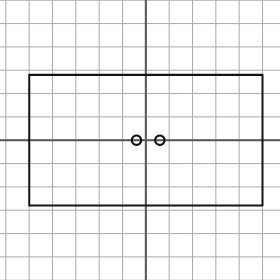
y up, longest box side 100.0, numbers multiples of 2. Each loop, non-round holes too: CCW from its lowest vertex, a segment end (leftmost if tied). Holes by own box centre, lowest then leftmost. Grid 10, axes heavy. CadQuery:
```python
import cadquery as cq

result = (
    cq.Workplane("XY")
    .moveTo(-50.0, -28.0)
    .lineTo(50.0, -28.0)
    .lineTo(50.0, 28.0)
    .lineTo(-50.0, 28.0)
    .close()
    .moveTo(-4.0, 0.0)
    .circle(2.0)
    .moveTo(6.0, 0.0)
    .circle(2.0)
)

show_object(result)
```